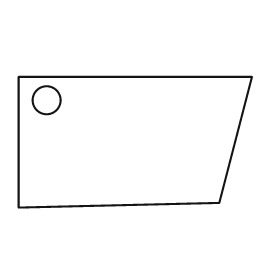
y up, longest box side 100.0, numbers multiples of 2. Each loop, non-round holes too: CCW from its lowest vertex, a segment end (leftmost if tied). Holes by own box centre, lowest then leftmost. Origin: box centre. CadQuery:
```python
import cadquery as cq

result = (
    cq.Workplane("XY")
    .moveTo(-50.0, -28.0)
    .lineTo(36.0, -26.0)
    .lineTo(50.0, 28.0)
    .lineTo(-50.0, 28.0)
    .close()
    .moveTo(-38.0, 18.0)
    .circle(6.0)
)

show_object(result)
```